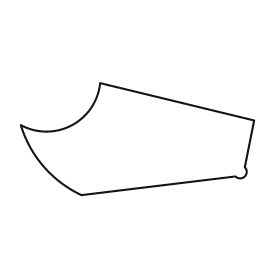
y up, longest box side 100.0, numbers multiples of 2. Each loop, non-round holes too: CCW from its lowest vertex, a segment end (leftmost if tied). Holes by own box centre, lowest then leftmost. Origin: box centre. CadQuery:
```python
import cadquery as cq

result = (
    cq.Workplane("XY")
    .moveTo(-24.0, -24.0)
    .lineTo(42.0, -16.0)
    .threePointArc((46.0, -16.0), (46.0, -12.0))
    .lineTo(50.0, 8.0)
    .lineTo(-16.0, 24.0)
    .threePointArc((-28.0, 6.0), (-50.0, 6.0))
    .threePointArc((-40.0, -12.0), (-24.0, -24.0))
    .close()
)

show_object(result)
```